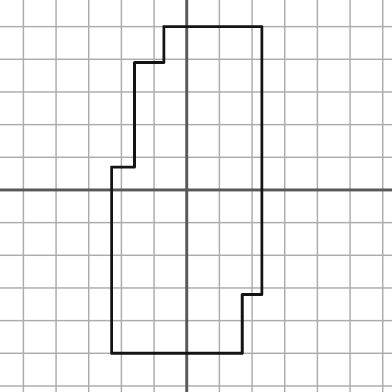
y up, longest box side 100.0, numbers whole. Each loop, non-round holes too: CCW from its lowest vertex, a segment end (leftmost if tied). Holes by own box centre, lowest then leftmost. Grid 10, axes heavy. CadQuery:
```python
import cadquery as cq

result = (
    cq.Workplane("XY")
    .moveTo(-23.0, -50.0)
    .lineTo(17.0, -50.0)
    .lineTo(17.0, -32.0)
    .lineTo(23.0, -32.0)
    .lineTo(23.0, 50.0)
    .lineTo(-7.0, 50.0)
    .lineTo(-7.0, 39.0)
    .lineTo(-16.0, 39.0)
    .lineTo(-16.0, 7.0)
    .lineTo(-23.0, 7.0)
    .close()
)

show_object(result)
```